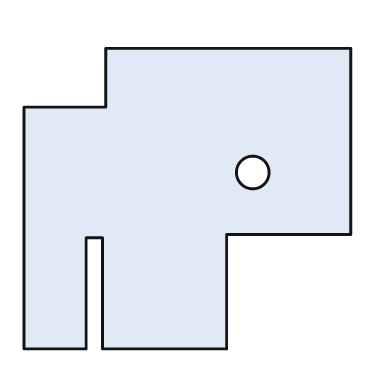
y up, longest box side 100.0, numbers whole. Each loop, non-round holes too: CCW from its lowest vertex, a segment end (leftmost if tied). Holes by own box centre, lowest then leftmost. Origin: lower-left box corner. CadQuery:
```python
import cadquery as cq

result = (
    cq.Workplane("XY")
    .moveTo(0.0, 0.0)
    .lineTo(19.0, 0.0)
    .lineTo(19.0, 34.0)
    .lineTo(24.0, 34.0)
    .lineTo(24.0, 0.0)
    .lineTo(62.0, 0.0)
    .lineTo(62.0, 35.0)
    .lineTo(100.0, 35.0)
    .lineTo(100.0, 92.0)
    .lineTo(25.0, 92.0)
    .lineTo(25.0, 74.0)
    .lineTo(0.0, 74.0)
    .close()
    .moveTo(70.0, 54.0)
    .circle(5.0)
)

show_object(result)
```